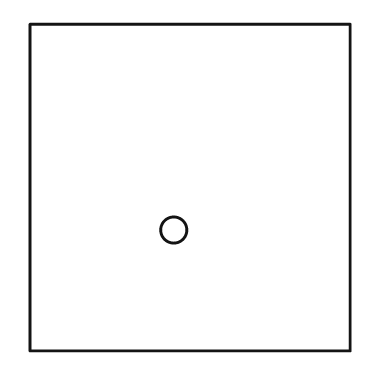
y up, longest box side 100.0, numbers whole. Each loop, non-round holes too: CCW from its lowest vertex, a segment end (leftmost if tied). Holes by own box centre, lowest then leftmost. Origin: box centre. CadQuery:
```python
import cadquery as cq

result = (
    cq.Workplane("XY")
    .moveTo(-49.0, -50.0)
    .lineTo(49.0, -50.0)
    .lineTo(49.0, 50.0)
    .lineTo(-49.0, 50.0)
    .close()
    .moveTo(-5.0, -13.0)
    .circle(4.0)
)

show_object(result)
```